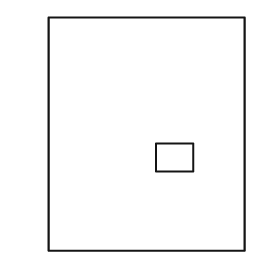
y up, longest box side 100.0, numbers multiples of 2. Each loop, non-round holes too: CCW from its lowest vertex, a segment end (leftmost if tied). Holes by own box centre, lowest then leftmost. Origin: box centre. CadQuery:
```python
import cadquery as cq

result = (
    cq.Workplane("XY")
    .moveTo(-42.0, -50.0)
    .lineTo(42.0, -50.0)
    .lineTo(42.0, 50.0)
    .lineTo(-42.0, 50.0)
    .close()
    .moveTo(4.0, -16.0)
    .lineTo(20.0, -16.0)
    .lineTo(20.0, -4.0)
    .lineTo(4.0, -4.0)
    .close()
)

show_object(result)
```